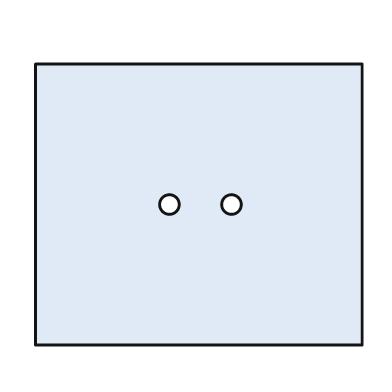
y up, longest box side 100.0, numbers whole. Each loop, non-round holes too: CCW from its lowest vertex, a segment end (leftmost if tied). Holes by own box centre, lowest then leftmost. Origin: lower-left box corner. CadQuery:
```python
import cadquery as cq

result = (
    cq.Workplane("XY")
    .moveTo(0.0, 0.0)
    .lineTo(100.0, 0.0)
    .lineTo(100.0, 86.0)
    .lineTo(0.0, 86.0)
    .close()
    .moveTo(41.0, 43.0)
    .circle(3.0)
    .moveTo(60.0, 43.0)
    .circle(3.0)
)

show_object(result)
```